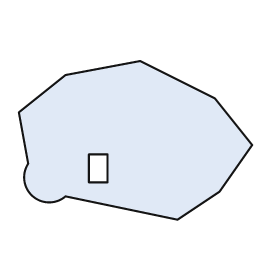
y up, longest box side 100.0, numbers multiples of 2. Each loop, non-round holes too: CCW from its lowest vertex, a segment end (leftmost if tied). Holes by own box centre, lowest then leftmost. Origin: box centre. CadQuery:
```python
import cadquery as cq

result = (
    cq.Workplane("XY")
    .moveTo(18.0, -34.0)
    .lineTo(36.0, -22.0)
    .lineTo(50.0, -2.0)
    .lineTo(34.0, 18.0)
    .lineTo(2.0, 34.0)
    .lineTo(-30.0, 28.0)
    .lineTo(-50.0, 12.0)
    .lineTo(-46.0, -10.0)
    .threePointArc((-44.0, -24.0), (-30.0, -24.0))
    .close()
    .moveTo(-20.0, -18.0)
    .lineTo(-12.0, -18.0)
    .lineTo(-12.0, -6.0)
    .lineTo(-20.0, -6.0)
    .close()
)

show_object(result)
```